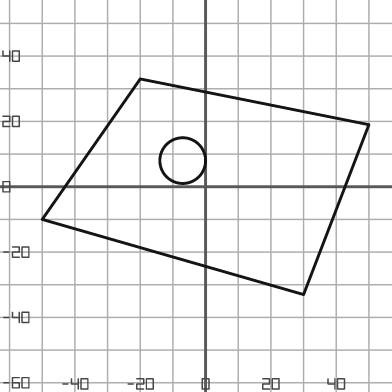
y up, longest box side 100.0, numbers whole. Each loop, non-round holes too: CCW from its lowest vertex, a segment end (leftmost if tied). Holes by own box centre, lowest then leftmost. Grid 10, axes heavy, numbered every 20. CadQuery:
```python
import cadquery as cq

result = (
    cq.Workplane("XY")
    .moveTo(30.0, -33.0)
    .lineTo(50.0, 19.0)
    .lineTo(-20.0, 33.0)
    .lineTo(-50.0, -10.0)
    .close()
    .moveTo(-7.0, 8.0)
    .circle(7.0)
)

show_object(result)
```